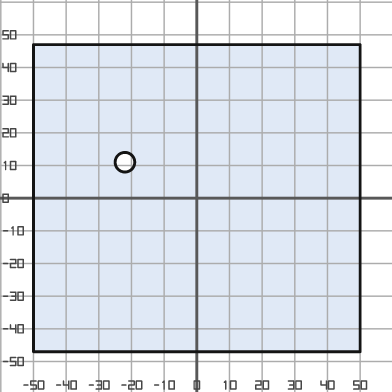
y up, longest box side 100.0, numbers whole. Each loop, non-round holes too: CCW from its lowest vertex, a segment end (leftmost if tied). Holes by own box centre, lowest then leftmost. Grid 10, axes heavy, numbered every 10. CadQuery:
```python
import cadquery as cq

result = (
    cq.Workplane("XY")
    .moveTo(-50.0, -47.0)
    .lineTo(50.0, -47.0)
    .lineTo(50.0, 47.0)
    .lineTo(-50.0, 47.0)
    .close()
    .moveTo(-22.0, 11.0)
    .circle(3.0)
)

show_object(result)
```